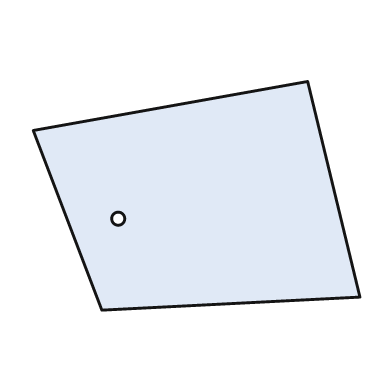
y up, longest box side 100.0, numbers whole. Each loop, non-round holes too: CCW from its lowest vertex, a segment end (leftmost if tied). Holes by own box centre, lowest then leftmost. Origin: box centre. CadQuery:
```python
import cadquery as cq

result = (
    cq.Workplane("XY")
    .moveTo(-29.0, -35.0)
    .lineTo(50.0, -31.0)
    .lineTo(34.0, 35.0)
    .lineTo(-50.0, 20.0)
    .close()
    .moveTo(-24.0, -7.0)
    .circle(2.0)
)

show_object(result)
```